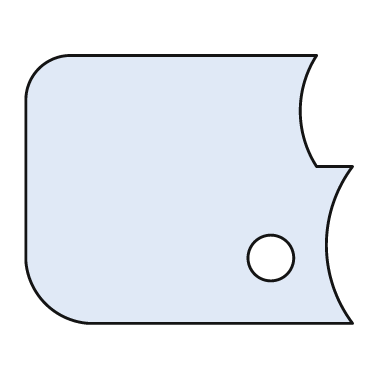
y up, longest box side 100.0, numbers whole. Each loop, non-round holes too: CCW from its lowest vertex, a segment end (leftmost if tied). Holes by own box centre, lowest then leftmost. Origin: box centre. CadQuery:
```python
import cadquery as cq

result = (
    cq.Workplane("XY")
    .moveTo(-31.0, -41.0)
    .lineTo(50.0, -41.0)
    .threePointArc((42.0, -17.0), (50.0, 7.0))
    .lineTo(39.0, 7.0)
    .threePointArc((34.0, 24.0), (39.0, 41.0))
    .lineTo(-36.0, 41.0)
    .threePointArc((-46.0, 37.0), (-50.0, 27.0))
    .lineTo(-50.0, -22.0)
    .threePointArc((-44.0, -35.0), (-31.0, -41.0))
    .close()
    .moveTo(25.0, -21.0)
    .circle(7.0)
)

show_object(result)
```